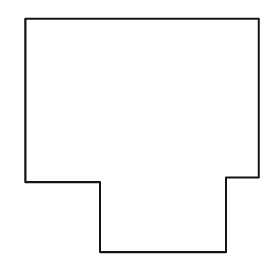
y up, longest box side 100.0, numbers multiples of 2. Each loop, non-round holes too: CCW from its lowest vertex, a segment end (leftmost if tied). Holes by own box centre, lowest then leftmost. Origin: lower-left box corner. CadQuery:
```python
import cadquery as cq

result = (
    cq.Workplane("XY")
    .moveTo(32.0, 0.0)
    .lineTo(86.0, 0.0)
    .lineTo(86.0, 32.0)
    .lineTo(100.0, 32.0)
    .lineTo(100.0, 100.0)
    .lineTo(0.0, 100.0)
    .lineTo(0.0, 30.0)
    .lineTo(32.0, 30.0)
    .close()
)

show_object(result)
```